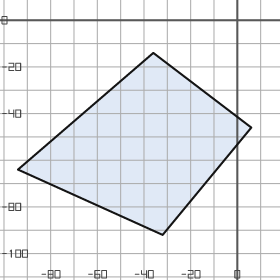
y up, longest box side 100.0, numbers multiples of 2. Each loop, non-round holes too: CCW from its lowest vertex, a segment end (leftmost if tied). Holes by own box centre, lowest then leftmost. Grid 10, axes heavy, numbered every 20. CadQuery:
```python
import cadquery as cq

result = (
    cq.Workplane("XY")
    .moveTo(-32.0, -92.0)
    .lineTo(6.0, -46.0)
    .lineTo(-36.0, -14.0)
    .lineTo(-94.0, -64.0)
    .close()
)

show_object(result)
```